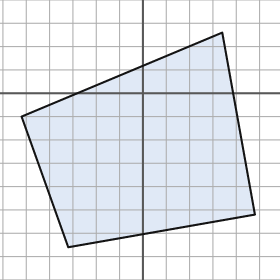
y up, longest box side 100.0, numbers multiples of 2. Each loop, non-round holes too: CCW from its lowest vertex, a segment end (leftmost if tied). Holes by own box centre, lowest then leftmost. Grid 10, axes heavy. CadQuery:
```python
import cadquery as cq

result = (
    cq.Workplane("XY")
    .moveTo(-32.0, -66.0)
    .lineTo(48.0, -52.0)
    .lineTo(34.0, 26.0)
    .lineTo(-52.0, -10.0)
    .close()
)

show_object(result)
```